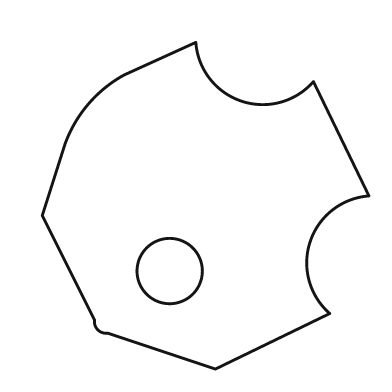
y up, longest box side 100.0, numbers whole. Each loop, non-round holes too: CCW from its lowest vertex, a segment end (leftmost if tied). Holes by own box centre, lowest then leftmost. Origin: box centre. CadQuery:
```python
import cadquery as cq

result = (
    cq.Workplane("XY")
    .moveTo(3.0, -50.0)
    .lineTo(38.0, -33.0)
    .threePointArc((32.0, -11.0), (50.0, 3.0))
    .lineTo(33.0, 38.0)
    .threePointArc((11.0, 32.0), (-3.0, 50.0))
    .lineTo(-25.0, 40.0)
    .threePointArc((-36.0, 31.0), (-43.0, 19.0))
    .lineTo(-50.0, -3.0)
    .lineTo(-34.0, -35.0)
    .threePointArc((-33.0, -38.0), (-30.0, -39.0))
    .close()
    .moveTo(-11.0, -20.0)
    .circle(10.0)
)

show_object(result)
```